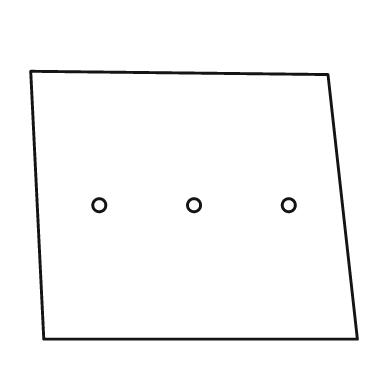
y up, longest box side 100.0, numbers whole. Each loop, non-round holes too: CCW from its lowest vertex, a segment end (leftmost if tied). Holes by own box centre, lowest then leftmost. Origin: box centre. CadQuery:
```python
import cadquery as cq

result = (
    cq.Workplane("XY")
    .moveTo(-46.0, -41.0)
    .lineTo(50.0, -41.0)
    .lineTo(41.0, 40.0)
    .lineTo(-50.0, 41.0)
    .close()
    .moveTo(-29.0, 0.0)
    .circle(2.0)
    .moveTo(0.0, 0.0)
    .circle(2.0)
    .moveTo(29.0, 0.0)
    .circle(2.0)
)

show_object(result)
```